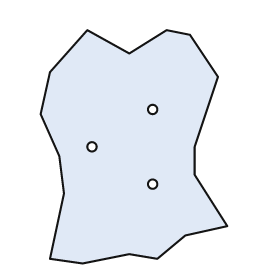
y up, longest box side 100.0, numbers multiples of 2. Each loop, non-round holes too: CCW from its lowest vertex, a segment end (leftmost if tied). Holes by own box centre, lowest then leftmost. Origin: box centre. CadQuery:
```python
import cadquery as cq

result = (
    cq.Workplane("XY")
    .moveTo(-22.0, -50.0)
    .lineTo(-2.0, -46.0)
    .lineTo(10.0, -48.0)
    .lineTo(22.0, -38.0)
    .lineTo(40.0, -34.0)
    .lineTo(26.0, -12.0)
    .lineTo(26.0, 0.0)
    .lineTo(36.0, 30.0)
    .lineTo(24.0, 48.0)
    .lineTo(14.0, 50.0)
    .lineTo(-2.0, 40.0)
    .lineTo(-20.0, 50.0)
    .lineTo(-36.0, 32.0)
    .lineTo(-40.0, 14.0)
    .lineTo(-32.0, -4.0)
    .lineTo(-30.0, -20.0)
    .lineTo(-36.0, -48.0)
    .close()
    .moveTo(8.0, -16.0)
    .circle(2.0)
    .moveTo(-18.0, 0.0)
    .circle(2.0)
    .moveTo(8.0, 16.0)
    .circle(2.0)
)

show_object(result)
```